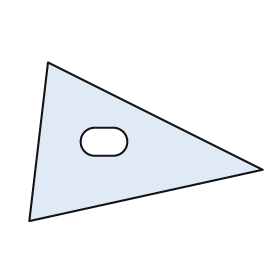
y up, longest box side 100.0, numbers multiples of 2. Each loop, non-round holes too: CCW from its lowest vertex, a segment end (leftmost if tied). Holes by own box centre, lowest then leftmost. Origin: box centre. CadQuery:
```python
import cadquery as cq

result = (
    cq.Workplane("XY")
    .moveTo(-50.0, -34.0)
    .lineTo(50.0, -12.0)
    .lineTo(-42.0, 34.0)
    .close()
    .moveTo(-22.0, -6.0)
    .lineTo(-14.0, -6.0)
    .threePointArc((-8.0, 0.0), (-14.0, 6.0))
    .lineTo(-22.0, 6.0)
    .threePointArc((-28.0, 0.0), (-22.0, -6.0))
    .close()
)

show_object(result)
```